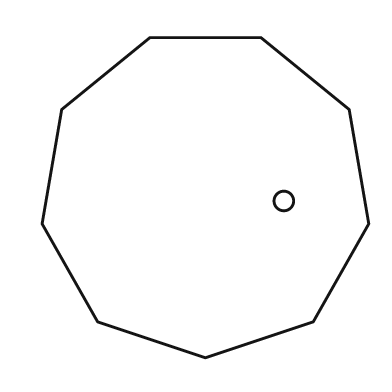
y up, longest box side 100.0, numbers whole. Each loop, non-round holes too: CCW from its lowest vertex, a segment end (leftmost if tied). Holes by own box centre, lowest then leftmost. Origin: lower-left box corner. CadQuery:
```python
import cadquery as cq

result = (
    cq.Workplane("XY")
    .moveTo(50.0, 0.0)
    .lineTo(83.0, 11.0)
    .lineTo(100.0, 41.0)
    .lineTo(94.0, 76.0)
    .lineTo(67.0, 98.0)
    .lineTo(33.0, 98.0)
    .lineTo(6.0, 76.0)
    .lineTo(0.0, 41.0)
    .lineTo(17.0, 11.0)
    .close()
    .moveTo(74.0, 48.0)
    .circle(3.0)
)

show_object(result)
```